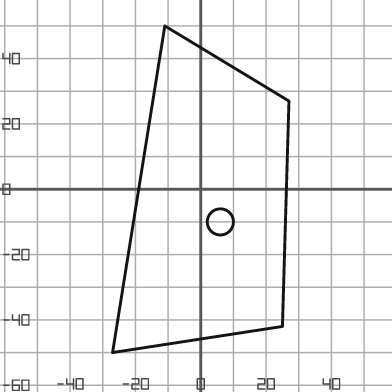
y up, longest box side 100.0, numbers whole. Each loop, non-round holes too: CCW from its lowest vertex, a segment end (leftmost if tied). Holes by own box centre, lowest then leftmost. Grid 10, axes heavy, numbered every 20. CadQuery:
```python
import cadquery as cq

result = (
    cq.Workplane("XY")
    .moveTo(-27.0, -50.0)
    .lineTo(25.0, -42.0)
    .lineTo(27.0, 27.0)
    .lineTo(-11.0, 50.0)
    .close()
    .moveTo(6.0, -10.0)
    .circle(4.0)
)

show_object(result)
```